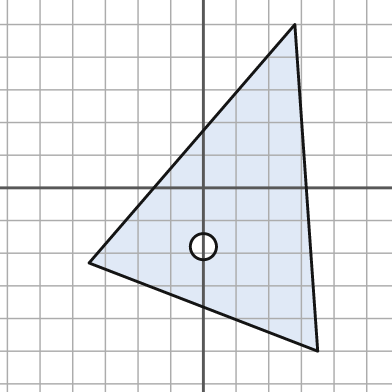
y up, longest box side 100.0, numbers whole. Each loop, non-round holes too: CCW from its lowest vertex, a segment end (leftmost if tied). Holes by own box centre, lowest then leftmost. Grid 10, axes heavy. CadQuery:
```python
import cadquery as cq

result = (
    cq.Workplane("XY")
    .moveTo(35.0, -50.0)
    .lineTo(28.0, 50.0)
    .lineTo(-35.0, -23.0)
    .close()
    .moveTo(0.0, -18.0)
    .circle(4.0)
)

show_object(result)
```